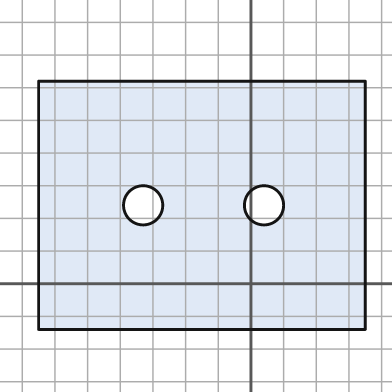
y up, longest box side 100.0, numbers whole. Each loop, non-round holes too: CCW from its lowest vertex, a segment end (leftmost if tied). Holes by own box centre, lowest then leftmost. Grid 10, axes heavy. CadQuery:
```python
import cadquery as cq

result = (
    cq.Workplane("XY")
    .moveTo(-65.0, -14.0)
    .lineTo(35.0, -14.0)
    .lineTo(35.0, 62.0)
    .lineTo(-65.0, 62.0)
    .close()
    .moveTo(-33.0, 24.0)
    .circle(6.0)
    .moveTo(4.0, 24.0)
    .circle(6.0)
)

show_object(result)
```